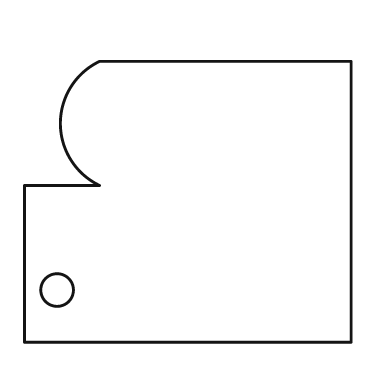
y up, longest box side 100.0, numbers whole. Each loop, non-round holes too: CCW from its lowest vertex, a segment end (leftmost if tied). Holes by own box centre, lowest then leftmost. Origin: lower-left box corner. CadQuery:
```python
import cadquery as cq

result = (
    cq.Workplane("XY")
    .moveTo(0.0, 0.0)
    .lineTo(100.0, 0.0)
    .lineTo(100.0, 86.0)
    .lineTo(23.0, 86.0)
    .threePointArc((11.0, 67.0), (23.0, 48.0))
    .lineTo(0.0, 48.0)
    .close()
    .moveTo(10.0, 16.0)
    .circle(5.0)
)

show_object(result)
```